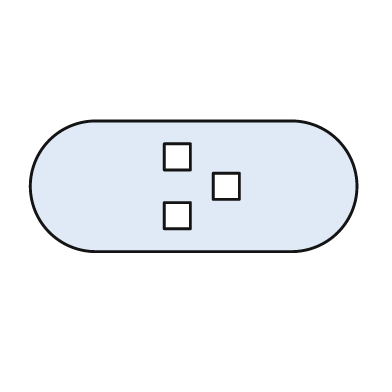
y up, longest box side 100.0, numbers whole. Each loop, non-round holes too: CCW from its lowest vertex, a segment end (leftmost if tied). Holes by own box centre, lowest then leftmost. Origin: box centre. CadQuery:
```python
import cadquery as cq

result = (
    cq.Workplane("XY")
    .moveTo(-30.0, -20.0)
    .lineTo(30.0, -20.0)
    .threePointArc((50.0, 0.0), (30.0, 20.0))
    .lineTo(-30.0, 20.0)
    .threePointArc((-50.0, 0.0), (-30.0, -20.0))
    .close()
    .moveTo(-9.0, -13.0)
    .lineTo(-1.0, -13.0)
    .lineTo(-1.0, -5.0)
    .lineTo(-9.0, -5.0)
    .close()
    .moveTo(6.0, -4.0)
    .lineTo(14.0, -4.0)
    .lineTo(14.0, 4.0)
    .lineTo(6.0, 4.0)
    .close()
    .moveTo(-9.0, 5.0)
    .lineTo(-1.0, 5.0)
    .lineTo(-1.0, 13.0)
    .lineTo(-9.0, 13.0)
    .close()
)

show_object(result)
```